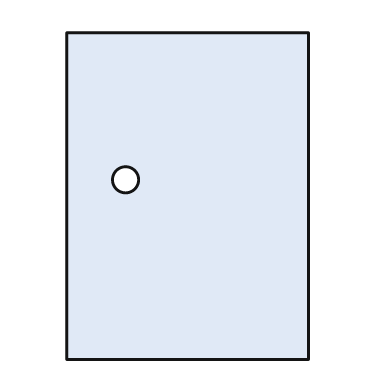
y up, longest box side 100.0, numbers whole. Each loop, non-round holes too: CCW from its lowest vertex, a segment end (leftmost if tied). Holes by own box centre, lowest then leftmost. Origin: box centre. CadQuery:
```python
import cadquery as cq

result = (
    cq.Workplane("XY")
    .moveTo(-37.0, -50.0)
    .lineTo(37.0, -50.0)
    .lineTo(37.0, 50.0)
    .lineTo(-37.0, 50.0)
    .close()
    .moveTo(-19.0, 5.0)
    .circle(4.0)
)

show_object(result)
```